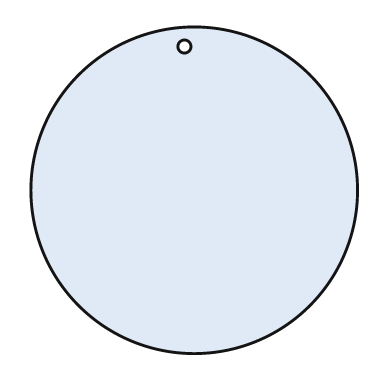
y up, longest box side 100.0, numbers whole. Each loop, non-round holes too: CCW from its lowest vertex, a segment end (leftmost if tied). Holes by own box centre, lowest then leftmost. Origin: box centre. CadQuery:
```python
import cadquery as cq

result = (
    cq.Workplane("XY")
    .moveTo(0.0, 0.0)
    .circle(50.0)
    .moveTo(-3.0, 44.0)
    .circle(2.0)
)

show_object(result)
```